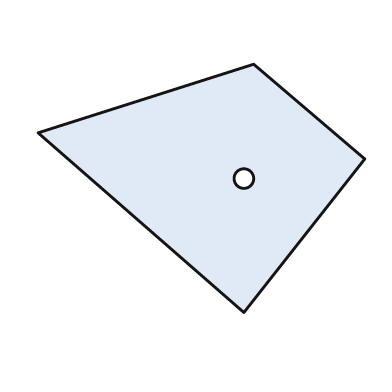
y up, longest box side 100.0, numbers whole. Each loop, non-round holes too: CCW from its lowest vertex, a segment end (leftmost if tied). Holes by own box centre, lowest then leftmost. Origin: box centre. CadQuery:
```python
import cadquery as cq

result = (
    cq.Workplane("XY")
    .moveTo(13.0, -38.0)
    .lineTo(50.0, 9.0)
    .lineTo(16.0, 38.0)
    .lineTo(-50.0, 17.0)
    .close()
    .moveTo(13.0, 3.0)
    .circle(3.0)
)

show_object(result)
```